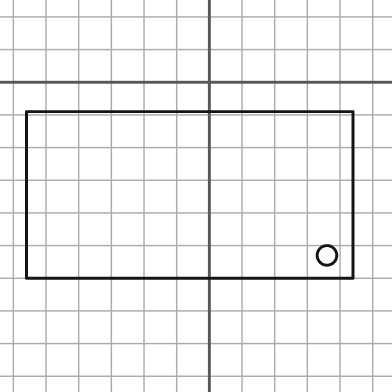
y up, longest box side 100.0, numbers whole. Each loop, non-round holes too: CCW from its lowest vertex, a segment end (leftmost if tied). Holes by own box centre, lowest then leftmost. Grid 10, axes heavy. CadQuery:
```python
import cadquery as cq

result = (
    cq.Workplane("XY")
    .moveTo(-56.0, -60.0)
    .lineTo(44.0, -60.0)
    .lineTo(44.0, -9.0)
    .lineTo(-56.0, -9.0)
    .close()
    .moveTo(36.0, -53.0)
    .circle(3.0)
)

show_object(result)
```